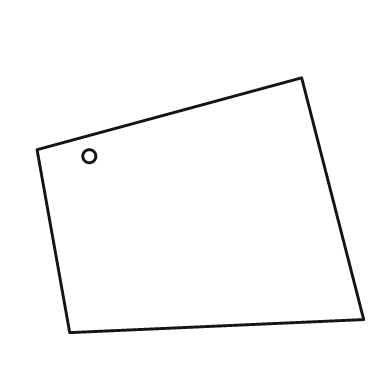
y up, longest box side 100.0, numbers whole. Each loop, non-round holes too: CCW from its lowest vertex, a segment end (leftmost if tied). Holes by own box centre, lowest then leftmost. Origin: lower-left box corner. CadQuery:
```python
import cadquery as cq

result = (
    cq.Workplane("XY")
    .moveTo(10.0, 0.0)
    .lineTo(100.0, 4.0)
    .lineTo(81.0, 78.0)
    .lineTo(0.0, 56.0)
    .close()
    .moveTo(16.0, 54.0)
    .circle(2.0)
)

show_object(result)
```